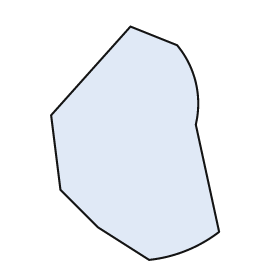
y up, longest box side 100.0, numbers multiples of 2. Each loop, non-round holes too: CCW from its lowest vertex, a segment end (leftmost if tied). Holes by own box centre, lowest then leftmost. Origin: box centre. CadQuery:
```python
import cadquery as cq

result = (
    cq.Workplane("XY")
    .moveTo(6.0, -50.0)
    .threePointArc((22.0, -46.0), (36.0, -38.0))
    .lineTo(26.0, 8.0)
    .threePointArc((26.0, 26.0), (18.0, 42.0))
    .lineTo(-2.0, 50.0)
    .lineTo(-36.0, 12.0)
    .lineTo(-32.0, -20.0)
    .lineTo(-16.0, -36.0)
    .close()
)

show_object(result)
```